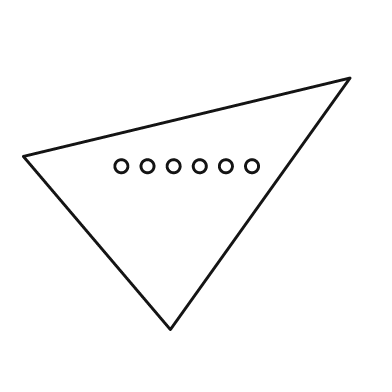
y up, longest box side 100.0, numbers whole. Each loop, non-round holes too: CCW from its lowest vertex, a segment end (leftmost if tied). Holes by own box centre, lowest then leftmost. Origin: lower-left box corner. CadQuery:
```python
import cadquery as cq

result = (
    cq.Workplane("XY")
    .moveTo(45.0, 0.0)
    .lineTo(100.0, 77.0)
    .lineTo(0.0, 53.0)
    .close()
    .moveTo(30.0, 50.0)
    .circle(2.0)
    .moveTo(38.0, 50.0)
    .circle(2.0)
    .moveTo(46.0, 50.0)
    .circle(2.0)
    .moveTo(54.0, 50.0)
    .circle(2.0)
    .moveTo(62.0, 50.0)
    .circle(2.0)
    .moveTo(70.0, 50.0)
    .circle(2.0)
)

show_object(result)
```